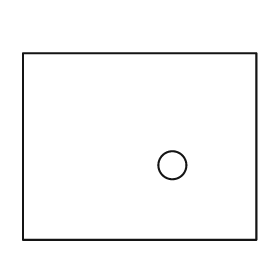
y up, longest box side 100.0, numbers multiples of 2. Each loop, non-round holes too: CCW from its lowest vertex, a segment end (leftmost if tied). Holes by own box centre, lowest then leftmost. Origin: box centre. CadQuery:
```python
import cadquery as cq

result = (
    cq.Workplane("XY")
    .moveTo(-50.0, -40.0)
    .lineTo(50.0, -40.0)
    .lineTo(50.0, 40.0)
    .lineTo(-50.0, 40.0)
    .close()
    .moveTo(14.0, -8.0)
    .circle(6.0)
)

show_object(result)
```